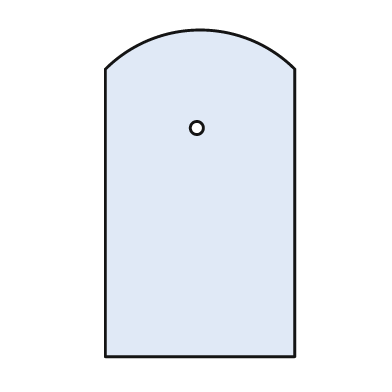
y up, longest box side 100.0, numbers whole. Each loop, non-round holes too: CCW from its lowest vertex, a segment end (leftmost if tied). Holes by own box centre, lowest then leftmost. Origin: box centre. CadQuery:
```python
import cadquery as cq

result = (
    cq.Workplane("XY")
    .moveTo(-29.0, -50.0)
    .lineTo(29.0, -50.0)
    .lineTo(29.0, 38.0)
    .threePointArc((0.0, 50.0), (-29.0, 38.0))
    .close()
    .moveTo(-1.0, 20.0)
    .circle(2.0)
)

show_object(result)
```